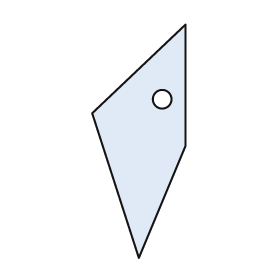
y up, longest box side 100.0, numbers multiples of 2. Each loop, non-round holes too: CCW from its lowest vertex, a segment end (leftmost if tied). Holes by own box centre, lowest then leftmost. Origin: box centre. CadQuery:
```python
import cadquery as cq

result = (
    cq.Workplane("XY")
    .moveTo(0.0, -50.0)
    .lineTo(20.0, -2.0)
    .lineTo(20.0, 50.0)
    .lineTo(-20.0, 12.0)
    .close()
    .moveTo(10.0, 18.0)
    .circle(4.0)
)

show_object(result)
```